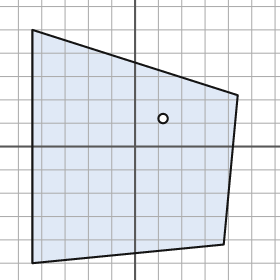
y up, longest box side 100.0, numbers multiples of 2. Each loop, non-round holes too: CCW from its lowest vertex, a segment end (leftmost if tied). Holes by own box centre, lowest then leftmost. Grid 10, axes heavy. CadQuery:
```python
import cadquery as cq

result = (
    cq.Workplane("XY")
    .moveTo(-44.0, -50.0)
    .lineTo(38.0, -42.0)
    .lineTo(44.0, 22.0)
    .lineTo(-44.0, 50.0)
    .close()
    .moveTo(12.0, 12.0)
    .circle(2.0)
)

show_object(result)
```